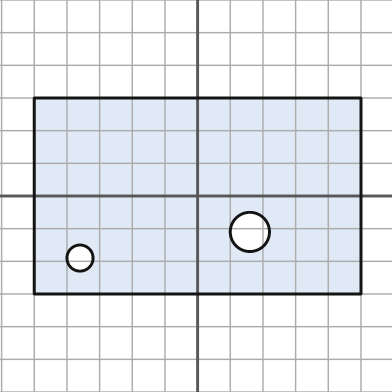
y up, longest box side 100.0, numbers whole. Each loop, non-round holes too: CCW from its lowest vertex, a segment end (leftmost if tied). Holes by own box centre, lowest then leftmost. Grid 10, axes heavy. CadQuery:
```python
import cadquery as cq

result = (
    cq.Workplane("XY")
    .moveTo(-50.0, -30.0)
    .lineTo(50.0, -30.0)
    .lineTo(50.0, 30.0)
    .lineTo(-50.0, 30.0)
    .close()
    .moveTo(-36.0, -19.0)
    .circle(4.0)
    .moveTo(16.0, -11.0)
    .circle(6.0)
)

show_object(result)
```